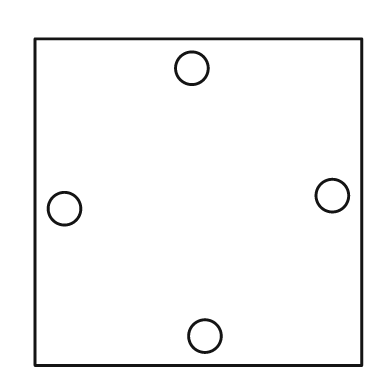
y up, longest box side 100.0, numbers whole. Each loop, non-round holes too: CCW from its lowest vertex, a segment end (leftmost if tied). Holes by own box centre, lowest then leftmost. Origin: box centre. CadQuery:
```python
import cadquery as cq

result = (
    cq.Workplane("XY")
    .moveTo(-50.0, -50.0)
    .lineTo(50.0, -50.0)
    .lineTo(50.0, 50.0)
    .lineTo(-50.0, 50.0)
    .close()
    .moveTo(2.0, -41.0)
    .circle(5.0)
    .moveTo(-41.0, -2.0)
    .circle(5.0)
    .moveTo(41.0, 2.0)
    .circle(5.0)
    .moveTo(-2.0, 41.0)
    .circle(5.0)
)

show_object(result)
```